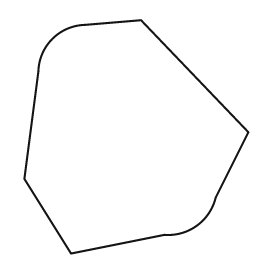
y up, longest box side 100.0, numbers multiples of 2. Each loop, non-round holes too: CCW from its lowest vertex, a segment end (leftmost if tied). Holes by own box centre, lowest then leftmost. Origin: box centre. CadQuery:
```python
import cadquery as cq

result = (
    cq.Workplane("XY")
    .moveTo(-28.0, -50.0)
    .lineTo(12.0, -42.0)
    .threePointArc((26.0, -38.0), (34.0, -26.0))
    .lineTo(48.0, 2.0)
    .lineTo(2.0, 50.0)
    .lineTo(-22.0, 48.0)
    .threePointArc((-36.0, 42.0), (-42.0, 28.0))
    .lineTo(-48.0, -18.0)
    .close()
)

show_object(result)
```